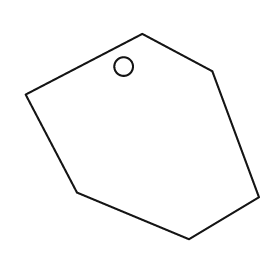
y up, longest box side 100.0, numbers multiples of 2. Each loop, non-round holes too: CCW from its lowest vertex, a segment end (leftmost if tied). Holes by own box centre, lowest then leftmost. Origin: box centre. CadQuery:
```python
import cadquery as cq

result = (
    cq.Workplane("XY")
    .moveTo(20.0, -44.0)
    .lineTo(50.0, -26.0)
    .lineTo(30.0, 28.0)
    .lineTo(0.0, 44.0)
    .lineTo(-50.0, 18.0)
    .lineTo(-28.0, -24.0)
    .close()
    .moveTo(-8.0, 30.0)
    .circle(4.0)
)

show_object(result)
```